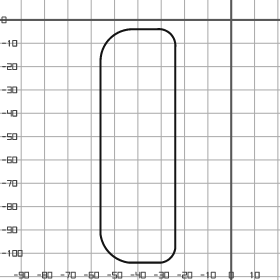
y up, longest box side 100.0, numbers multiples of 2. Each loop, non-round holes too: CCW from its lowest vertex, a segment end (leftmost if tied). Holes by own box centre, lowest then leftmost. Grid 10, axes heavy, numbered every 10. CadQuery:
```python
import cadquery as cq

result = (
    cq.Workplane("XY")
    .moveTo(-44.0, -104.0)
    .lineTo(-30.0, -104.0)
    .threePointArc((-26.0, -102.0), (-24.0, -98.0))
    .lineTo(-24.0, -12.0)
    .threePointArc((-26.0, -6.0), (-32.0, -4.0))
    .lineTo(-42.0, -4.0)
    .threePointArc((-52.0, -8.0), (-56.0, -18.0))
    .lineTo(-56.0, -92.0)
    .threePointArc((-52.0, -100.0), (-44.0, -104.0))
    .close()
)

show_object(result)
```